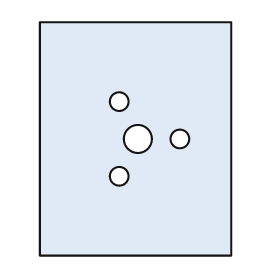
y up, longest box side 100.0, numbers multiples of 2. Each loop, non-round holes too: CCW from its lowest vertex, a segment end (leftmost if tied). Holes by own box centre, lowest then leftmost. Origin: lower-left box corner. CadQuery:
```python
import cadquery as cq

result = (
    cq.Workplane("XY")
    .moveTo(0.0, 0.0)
    .lineTo(82.0, 0.0)
    .lineTo(82.0, 100.0)
    .lineTo(0.0, 100.0)
    .close()
    .moveTo(34.0, 34.0)
    .circle(4.0)
    .moveTo(42.0, 50.0)
    .circle(6.0)
    .moveTo(60.0, 50.0)
    .circle(4.0)
    .moveTo(34.0, 66.0)
    .circle(4.0)
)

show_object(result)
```